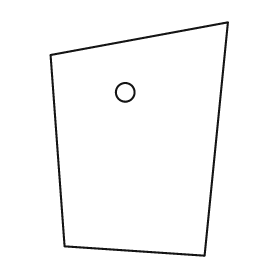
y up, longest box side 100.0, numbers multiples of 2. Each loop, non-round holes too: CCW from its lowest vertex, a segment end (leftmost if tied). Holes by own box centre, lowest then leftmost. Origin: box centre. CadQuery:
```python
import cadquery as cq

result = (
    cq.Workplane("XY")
    .moveTo(28.0, -50.0)
    .lineTo(38.0, 50.0)
    .lineTo(-38.0, 36.0)
    .lineTo(-32.0, -46.0)
    .close()
    .moveTo(-6.0, 20.0)
    .circle(4.0)
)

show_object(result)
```